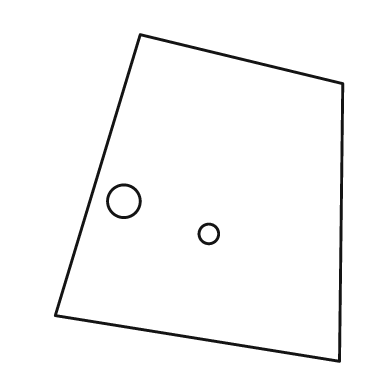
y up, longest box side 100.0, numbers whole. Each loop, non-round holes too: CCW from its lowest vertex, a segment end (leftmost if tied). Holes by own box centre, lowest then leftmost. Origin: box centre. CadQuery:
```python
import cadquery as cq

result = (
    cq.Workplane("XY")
    .moveTo(43.0, -50.0)
    .lineTo(44.0, 35.0)
    .lineTo(-18.0, 50.0)
    .lineTo(-44.0, -36.0)
    .close()
    .moveTo(3.0, -11.0)
    .circle(3.0)
    .moveTo(-23.0, -1.0)
    .circle(5.0)
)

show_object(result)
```